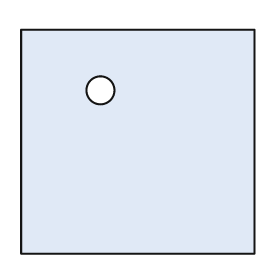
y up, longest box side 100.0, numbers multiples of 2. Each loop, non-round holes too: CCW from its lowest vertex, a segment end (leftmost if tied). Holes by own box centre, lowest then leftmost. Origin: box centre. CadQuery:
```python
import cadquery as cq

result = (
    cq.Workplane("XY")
    .moveTo(-50.0, -48.0)
    .lineTo(50.0, -48.0)
    .lineTo(50.0, 48.0)
    .lineTo(-50.0, 48.0)
    .close()
    .moveTo(-16.0, 22.0)
    .circle(6.0)
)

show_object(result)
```